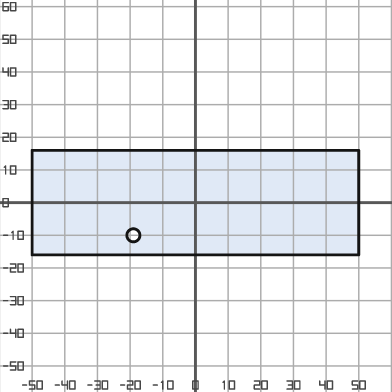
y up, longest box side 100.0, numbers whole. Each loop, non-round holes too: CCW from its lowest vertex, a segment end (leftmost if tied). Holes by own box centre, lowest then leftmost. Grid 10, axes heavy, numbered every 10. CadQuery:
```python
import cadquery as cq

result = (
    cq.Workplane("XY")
    .moveTo(-50.0, -16.0)
    .lineTo(50.0, -16.0)
    .lineTo(50.0, 16.0)
    .lineTo(-50.0, 16.0)
    .close()
    .moveTo(-19.0, -10.0)
    .circle(2.0)
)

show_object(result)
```